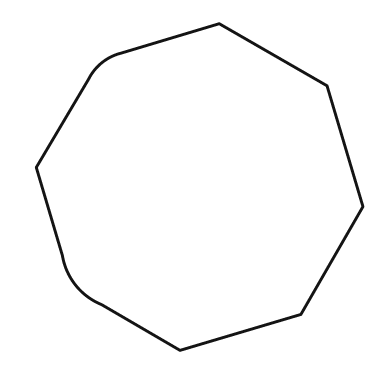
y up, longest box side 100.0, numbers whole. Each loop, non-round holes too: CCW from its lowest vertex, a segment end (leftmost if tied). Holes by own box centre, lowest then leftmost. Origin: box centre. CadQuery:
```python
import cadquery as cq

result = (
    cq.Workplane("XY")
    .moveTo(-6.0, -50.0)
    .lineTo(31.0, -39.0)
    .lineTo(50.0, -6.0)
    .lineTo(39.0, 31.0)
    .lineTo(6.0, 50.0)
    .lineTo(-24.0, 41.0)
    .threePointArc((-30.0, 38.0), (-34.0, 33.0))
    .lineTo(-50.0, 6.0)
    .lineTo(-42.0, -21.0)
    .threePointArc((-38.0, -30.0), (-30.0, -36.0))
    .close()
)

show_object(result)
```